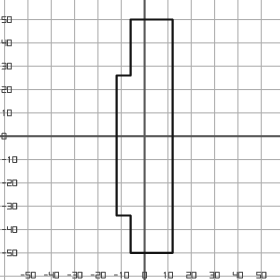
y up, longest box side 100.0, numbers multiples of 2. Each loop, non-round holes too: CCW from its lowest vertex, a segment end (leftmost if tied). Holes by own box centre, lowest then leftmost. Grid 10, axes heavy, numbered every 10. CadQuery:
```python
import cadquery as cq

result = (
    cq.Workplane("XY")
    .moveTo(-6.0, -50.0)
    .lineTo(12.0, -50.0)
    .lineTo(12.0, 50.0)
    .lineTo(-6.0, 50.0)
    .lineTo(-6.0, 26.0)
    .lineTo(-12.0, 26.0)
    .lineTo(-12.0, -34.0)
    .lineTo(-6.0, -34.0)
    .close()
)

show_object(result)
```